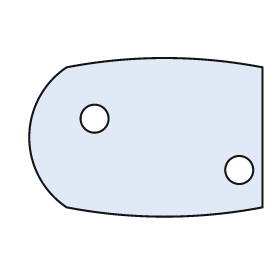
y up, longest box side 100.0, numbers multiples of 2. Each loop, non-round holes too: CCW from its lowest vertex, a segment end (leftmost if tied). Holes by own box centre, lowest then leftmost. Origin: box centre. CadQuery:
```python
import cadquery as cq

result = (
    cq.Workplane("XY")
    .moveTo(-34.0, -30.0)
    .threePointArc((8.0, -34.0), (50.0, -30.0))
    .lineTo(50.0, 30.0)
    .threePointArc((8.0, 34.0), (-34.0, 30.0))
    .threePointArc((-50.0, 0.0), (-34.0, -30.0))
    .close()
    .moveTo(40.0, -14.0)
    .circle(6.0)
    .moveTo(-22.0, 8.0)
    .circle(6.0)
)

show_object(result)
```